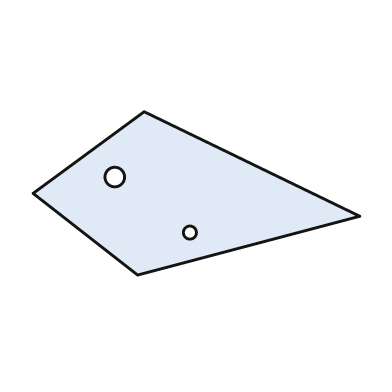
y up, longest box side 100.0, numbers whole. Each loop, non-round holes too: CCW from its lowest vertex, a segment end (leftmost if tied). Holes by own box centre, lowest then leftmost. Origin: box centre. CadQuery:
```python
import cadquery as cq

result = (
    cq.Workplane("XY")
    .moveTo(-18.0, -25.0)
    .lineTo(50.0, -7.0)
    .lineTo(-16.0, 25.0)
    .lineTo(-50.0, 0.0)
    .close()
    .moveTo(-2.0, -12.0)
    .circle(2.0)
    .moveTo(-25.0, 5.0)
    .circle(3.0)
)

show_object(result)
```